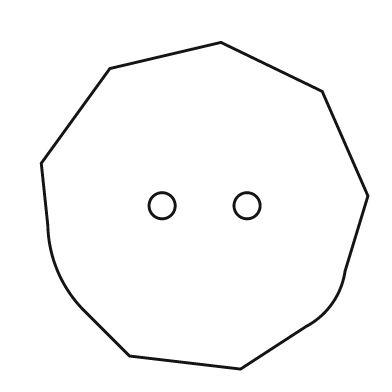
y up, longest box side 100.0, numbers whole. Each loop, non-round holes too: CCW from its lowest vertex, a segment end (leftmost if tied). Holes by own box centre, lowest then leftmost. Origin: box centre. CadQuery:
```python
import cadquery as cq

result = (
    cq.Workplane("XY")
    .moveTo(11.0, -50.0)
    .lineTo(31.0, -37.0)
    .threePointArc((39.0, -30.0), (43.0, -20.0))
    .lineTo(50.0, 3.0)
    .lineTo(36.0, 35.0)
    .lineTo(5.0, 50.0)
    .lineTo(-29.0, 42.0)
    .lineTo(-50.0, 13.0)
    .lineTo(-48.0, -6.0)
    .threePointArc((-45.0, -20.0), (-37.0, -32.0))
    .lineTo(-23.0, -46.0)
    .close()
    .moveTo(-13.0, 0.0)
    .circle(4.0)
    .moveTo(13.0, 0.0)
    .circle(4.0)
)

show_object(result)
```